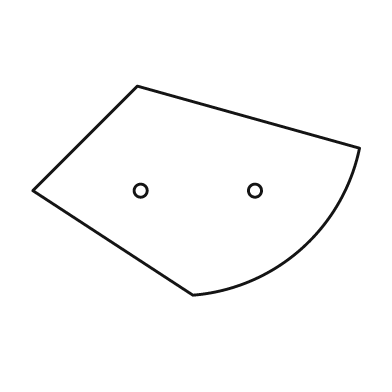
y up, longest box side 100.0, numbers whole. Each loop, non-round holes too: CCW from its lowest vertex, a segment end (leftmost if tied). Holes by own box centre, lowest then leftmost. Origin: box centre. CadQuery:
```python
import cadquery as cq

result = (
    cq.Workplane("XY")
    .moveTo(-1.0, -32.0)
    .threePointArc((32.0, -18.0), (50.0, 13.0))
    .lineTo(-18.0, 32.0)
    .lineTo(-50.0, 0.0)
    .close()
    .moveTo(-17.0, 0.0)
    .circle(2.0)
    .moveTo(18.0, 0.0)
    .circle(2.0)
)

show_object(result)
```